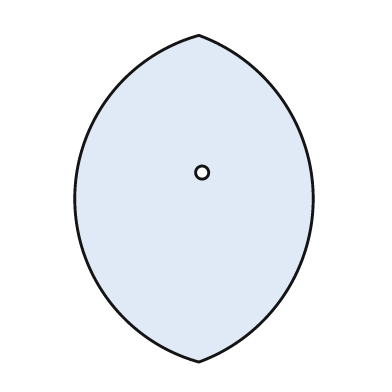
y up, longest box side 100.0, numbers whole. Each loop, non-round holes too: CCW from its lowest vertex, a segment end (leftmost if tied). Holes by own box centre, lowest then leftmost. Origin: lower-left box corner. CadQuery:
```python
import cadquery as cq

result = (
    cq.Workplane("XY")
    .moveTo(38.0, 0.0)
    .threePointArc((73.0, 50.0), (38.0, 100.0))
    .threePointArc((0.0, 50.0), (38.0, 0.0))
    .close()
    .moveTo(39.0, 58.0)
    .circle(2.0)
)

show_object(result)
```